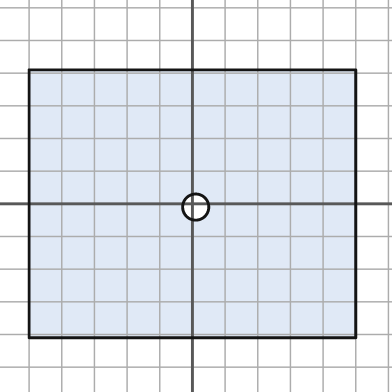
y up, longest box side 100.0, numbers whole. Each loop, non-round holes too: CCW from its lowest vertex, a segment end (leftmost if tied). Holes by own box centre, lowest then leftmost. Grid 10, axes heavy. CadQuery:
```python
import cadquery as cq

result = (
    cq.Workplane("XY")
    .moveTo(-50.0, -41.0)
    .lineTo(50.0, -41.0)
    .lineTo(50.0, 41.0)
    .lineTo(-50.0, 41.0)
    .close()
    .moveTo(1.0, -1.0)
    .circle(4.0)
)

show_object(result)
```